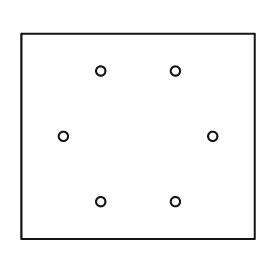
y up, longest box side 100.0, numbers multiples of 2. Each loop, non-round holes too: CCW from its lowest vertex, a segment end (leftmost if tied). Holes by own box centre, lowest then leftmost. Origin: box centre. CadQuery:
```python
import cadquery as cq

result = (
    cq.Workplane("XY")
    .moveTo(-50.0, -44.0)
    .lineTo(50.0, -44.0)
    .lineTo(50.0, 44.0)
    .lineTo(-50.0, 44.0)
    .close()
    .moveTo(-16.0, -28.0)
    .circle(2.0)
    .moveTo(16.0, -28.0)
    .circle(2.0)
    .moveTo(-32.0, 0.0)
    .circle(2.0)
    .moveTo(32.0, 0.0)
    .circle(2.0)
    .moveTo(-16.0, 28.0)
    .circle(2.0)
    .moveTo(16.0, 28.0)
    .circle(2.0)
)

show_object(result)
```